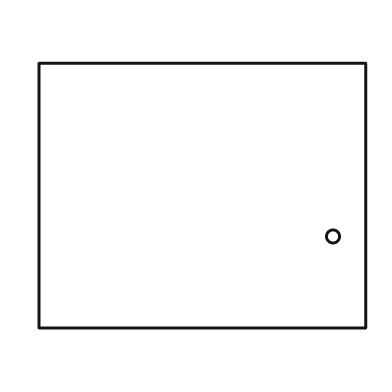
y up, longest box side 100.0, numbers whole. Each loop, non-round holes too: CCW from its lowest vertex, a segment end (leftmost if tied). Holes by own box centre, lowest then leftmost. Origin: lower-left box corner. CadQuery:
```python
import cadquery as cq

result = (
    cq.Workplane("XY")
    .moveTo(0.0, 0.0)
    .lineTo(100.0, 0.0)
    .lineTo(100.0, 81.0)
    .lineTo(0.0, 81.0)
    .close()
    .moveTo(90.0, 28.0)
    .circle(2.0)
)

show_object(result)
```